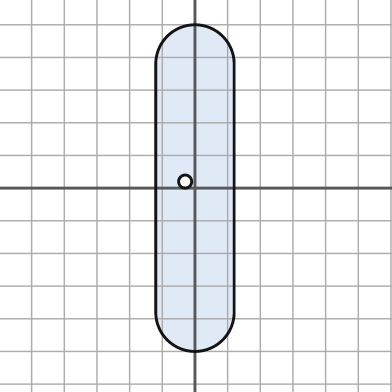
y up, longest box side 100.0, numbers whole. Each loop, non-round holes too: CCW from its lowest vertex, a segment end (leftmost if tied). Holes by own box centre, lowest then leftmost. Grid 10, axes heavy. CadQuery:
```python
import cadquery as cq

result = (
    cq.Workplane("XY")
    .moveTo(-12.0, -38.0)
    .threePointArc((0.0, -50.0), (12.0, -38.0))
    .lineTo(12.0, 38.0)
    .threePointArc((0.0, 50.0), (-12.0, 38.0))
    .close()
    .moveTo(-3.0, 2.0)
    .circle(2.0)
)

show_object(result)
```